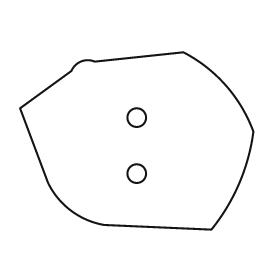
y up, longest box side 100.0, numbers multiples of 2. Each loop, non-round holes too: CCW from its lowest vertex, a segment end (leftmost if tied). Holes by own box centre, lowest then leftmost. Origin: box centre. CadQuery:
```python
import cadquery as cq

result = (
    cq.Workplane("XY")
    .moveTo(32.0, -38.0)
    .threePointArc((44.0, -18.0), (50.0, 4.0))
    .threePointArc((38.0, 24.0), (20.0, 38.0))
    .lineTo(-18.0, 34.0)
    .threePointArc((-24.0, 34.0), (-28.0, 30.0))
    .lineTo(-50.0, 14.0)
    .lineTo(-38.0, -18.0)
    .threePointArc((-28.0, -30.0), (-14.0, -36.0))
    .close()
    .moveTo(0.0, -14.0)
    .circle(4.0)
    .moveTo(0.0, 10.0)
    .circle(4.0)
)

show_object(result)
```